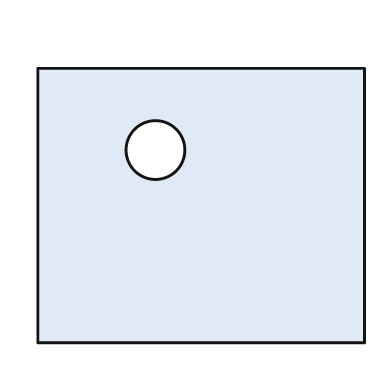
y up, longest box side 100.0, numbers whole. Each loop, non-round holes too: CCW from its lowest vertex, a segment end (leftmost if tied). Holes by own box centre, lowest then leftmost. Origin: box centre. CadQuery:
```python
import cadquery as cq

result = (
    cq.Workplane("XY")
    .moveTo(-50.0, -42.0)
    .lineTo(50.0, -42.0)
    .lineTo(50.0, 42.0)
    .lineTo(-50.0, 42.0)
    .close()
    .moveTo(-14.0, 17.0)
    .circle(9.0)
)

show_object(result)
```